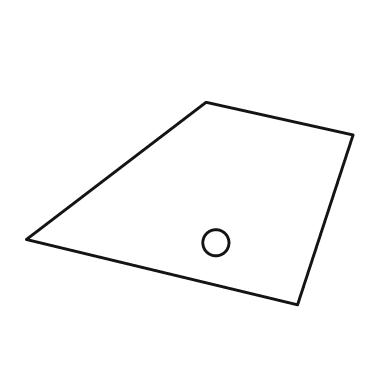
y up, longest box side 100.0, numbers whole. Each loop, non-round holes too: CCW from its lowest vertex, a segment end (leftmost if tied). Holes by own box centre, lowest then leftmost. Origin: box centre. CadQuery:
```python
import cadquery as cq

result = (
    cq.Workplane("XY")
    .moveTo(33.0, -31.0)
    .lineTo(50.0, 21.0)
    .lineTo(5.0, 31.0)
    .lineTo(-50.0, -11.0)
    .close()
    .moveTo(8.0, -12.0)
    .circle(4.0)
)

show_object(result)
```